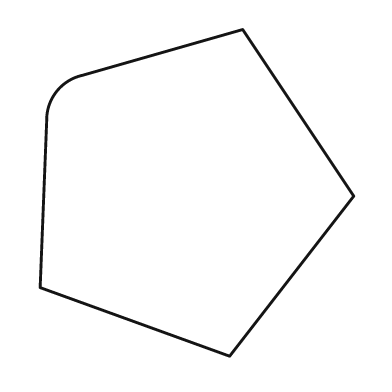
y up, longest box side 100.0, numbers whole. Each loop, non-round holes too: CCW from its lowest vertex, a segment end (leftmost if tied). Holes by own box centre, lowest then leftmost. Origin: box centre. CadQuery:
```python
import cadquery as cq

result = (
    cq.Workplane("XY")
    .moveTo(10.0, -50.0)
    .lineTo(48.0, -1.0)
    .lineTo(14.0, 50.0)
    .lineTo(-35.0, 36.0)
    .threePointArc((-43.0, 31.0), (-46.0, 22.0))
    .lineTo(-48.0, -29.0)
    .close()
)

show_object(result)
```